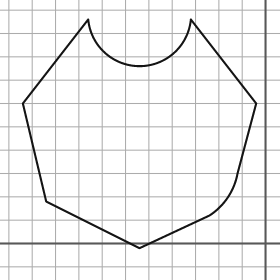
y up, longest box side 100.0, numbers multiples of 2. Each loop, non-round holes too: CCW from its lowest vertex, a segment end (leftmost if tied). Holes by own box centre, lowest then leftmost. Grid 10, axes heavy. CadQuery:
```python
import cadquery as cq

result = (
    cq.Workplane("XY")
    .moveTo(-54.0, -2.0)
    .lineTo(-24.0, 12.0)
    .threePointArc((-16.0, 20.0), (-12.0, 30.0))
    .lineTo(-4.0, 60.0)
    .lineTo(-32.0, 96.0)
    .threePointArc((-54.0, 76.0), (-76.0, 96.0))
    .lineTo(-104.0, 60.0)
    .lineTo(-94.0, 18.0)
    .close()
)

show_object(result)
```